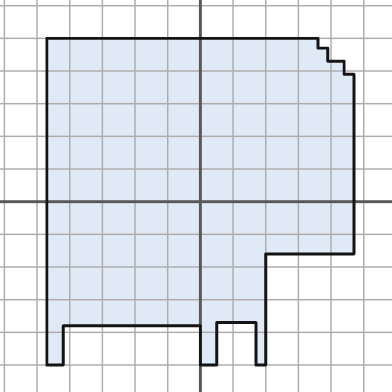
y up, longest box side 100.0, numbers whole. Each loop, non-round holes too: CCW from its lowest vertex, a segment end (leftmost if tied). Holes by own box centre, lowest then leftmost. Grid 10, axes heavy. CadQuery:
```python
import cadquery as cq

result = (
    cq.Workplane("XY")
    .moveTo(-47.0, -50.0)
    .lineTo(-42.0, -50.0)
    .lineTo(-42.0, -38.0)
    .lineTo(0.0, -38.0)
    .lineTo(0.0, -50.0)
    .lineTo(5.0, -50.0)
    .lineTo(5.0, -37.0)
    .lineTo(17.0, -37.0)
    .lineTo(17.0, -50.0)
    .lineTo(20.0, -50.0)
    .lineTo(20.0, -16.0)
    .lineTo(47.0, -16.0)
    .lineTo(47.0, 39.0)
    .lineTo(44.0, 39.0)
    .lineTo(44.0, 43.0)
    .lineTo(39.0, 43.0)
    .lineTo(39.0, 47.0)
    .lineTo(36.0, 47.0)
    .lineTo(36.0, 50.0)
    .lineTo(-47.0, 50.0)
    .close()
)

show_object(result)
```